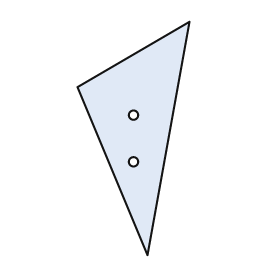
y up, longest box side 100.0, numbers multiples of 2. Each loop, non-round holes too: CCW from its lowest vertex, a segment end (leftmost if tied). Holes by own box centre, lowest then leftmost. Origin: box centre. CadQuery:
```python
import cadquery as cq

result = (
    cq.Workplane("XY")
    .moveTo(6.0, -50.0)
    .lineTo(24.0, 50.0)
    .lineTo(-24.0, 22.0)
    .close()
    .moveTo(0.0, -10.0)
    .circle(2.0)
    .moveTo(0.0, 10.0)
    .circle(2.0)
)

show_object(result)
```